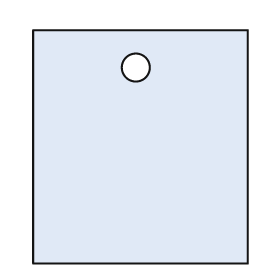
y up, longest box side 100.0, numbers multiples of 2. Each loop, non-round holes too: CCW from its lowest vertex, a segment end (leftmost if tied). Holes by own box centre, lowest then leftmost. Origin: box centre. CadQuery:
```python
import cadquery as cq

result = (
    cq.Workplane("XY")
    .moveTo(-46.0, -50.0)
    .lineTo(46.0, -50.0)
    .lineTo(46.0, 50.0)
    .lineTo(-46.0, 50.0)
    .close()
    .moveTo(-2.0, 34.0)
    .circle(6.0)
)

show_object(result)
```